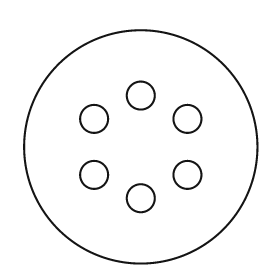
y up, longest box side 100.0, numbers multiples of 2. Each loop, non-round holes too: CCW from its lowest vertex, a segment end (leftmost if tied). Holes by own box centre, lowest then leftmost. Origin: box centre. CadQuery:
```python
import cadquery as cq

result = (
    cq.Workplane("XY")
    .moveTo(0.0, 0.0)
    .circle(50.0)
    .moveTo(0.0, -22.0)
    .circle(6.0)
    .moveTo(-20.0, -12.0)
    .circle(6.0)
    .moveTo(20.0, -12.0)
    .circle(6.0)
    .moveTo(-20.0, 12.0)
    .circle(6.0)
    .moveTo(20.0, 12.0)
    .circle(6.0)
    .moveTo(0.0, 22.0)
    .circle(6.0)
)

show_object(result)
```